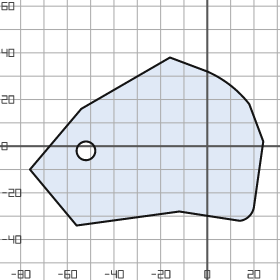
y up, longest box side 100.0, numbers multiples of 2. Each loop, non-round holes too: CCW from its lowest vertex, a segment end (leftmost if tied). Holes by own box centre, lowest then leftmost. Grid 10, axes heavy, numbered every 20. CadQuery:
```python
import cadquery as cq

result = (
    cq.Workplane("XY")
    .moveTo(-56.0, -34.0)
    .lineTo(-12.0, -28.0)
    .lineTo(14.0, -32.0)
    .threePointArc((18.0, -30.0), (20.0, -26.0))
    .lineTo(24.0, 2.0)
    .lineTo(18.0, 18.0)
    .threePointArc((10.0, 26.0), (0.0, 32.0))
    .lineTo(-16.0, 38.0)
    .lineTo(-54.0, 16.0)
    .lineTo(-76.0, -10.0)
    .close()
    .moveTo(-52.0, -2.0)
    .circle(4.0)
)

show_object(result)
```